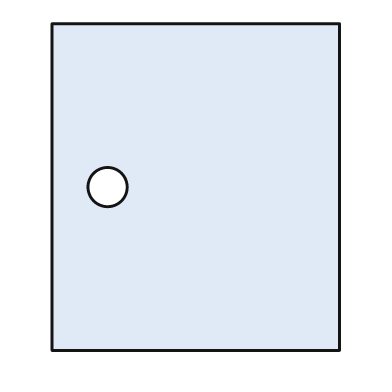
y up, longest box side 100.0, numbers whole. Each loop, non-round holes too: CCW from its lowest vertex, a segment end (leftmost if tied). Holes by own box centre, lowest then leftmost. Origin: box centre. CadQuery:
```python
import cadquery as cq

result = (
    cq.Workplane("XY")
    .moveTo(-44.0, -50.0)
    .lineTo(44.0, -50.0)
    .lineTo(44.0, 50.0)
    .lineTo(-44.0, 50.0)
    .close()
    .moveTo(-27.0, 0.0)
    .circle(6.0)
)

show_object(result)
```